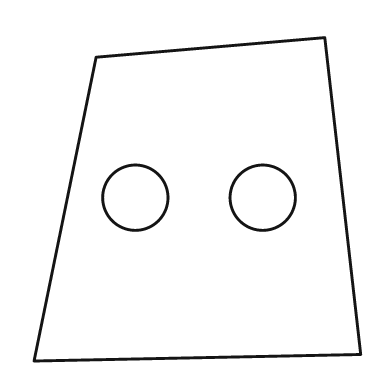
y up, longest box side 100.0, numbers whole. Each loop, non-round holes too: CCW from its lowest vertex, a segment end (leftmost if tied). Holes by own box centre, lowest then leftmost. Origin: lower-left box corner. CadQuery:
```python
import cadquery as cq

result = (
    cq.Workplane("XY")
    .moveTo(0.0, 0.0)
    .lineTo(100.0, 2.0)
    .lineTo(89.0, 99.0)
    .lineTo(19.0, 93.0)
    .close()
    .moveTo(31.0, 50.0)
    .circle(10.0)
    .moveTo(70.0, 50.0)
    .circle(10.0)
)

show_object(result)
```